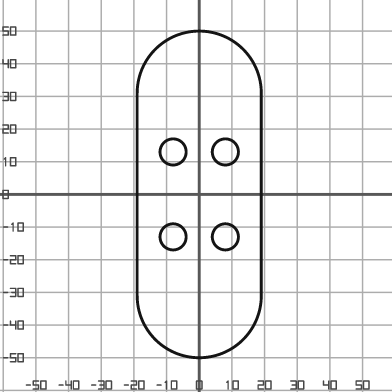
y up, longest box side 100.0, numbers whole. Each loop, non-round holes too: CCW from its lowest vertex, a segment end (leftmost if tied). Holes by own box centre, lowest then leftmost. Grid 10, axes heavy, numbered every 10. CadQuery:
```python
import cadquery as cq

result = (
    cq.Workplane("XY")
    .moveTo(-19.0, -31.0)
    .threePointArc((0.0, -50.0), (19.0, -31.0))
    .lineTo(19.0, 31.0)
    .threePointArc((0.0, 50.0), (-19.0, 31.0))
    .close()
    .moveTo(-8.0, -13.0)
    .circle(4.0)
    .moveTo(8.0, -13.0)
    .circle(4.0)
    .moveTo(-8.0, 13.0)
    .circle(4.0)
    .moveTo(8.0, 13.0)
    .circle(4.0)
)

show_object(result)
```